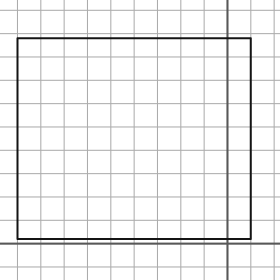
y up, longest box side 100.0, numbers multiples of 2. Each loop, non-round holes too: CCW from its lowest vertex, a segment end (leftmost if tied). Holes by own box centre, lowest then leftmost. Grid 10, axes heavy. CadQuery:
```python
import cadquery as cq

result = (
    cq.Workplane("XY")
    .moveTo(-90.0, 2.0)
    .lineTo(10.0, 2.0)
    .lineTo(10.0, 88.0)
    .lineTo(-90.0, 88.0)
    .close()
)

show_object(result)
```